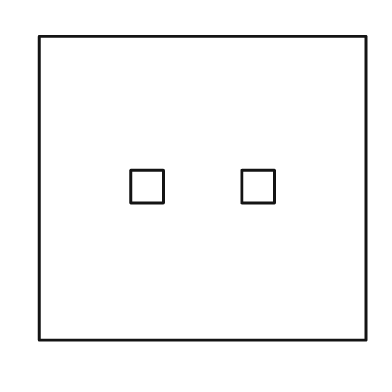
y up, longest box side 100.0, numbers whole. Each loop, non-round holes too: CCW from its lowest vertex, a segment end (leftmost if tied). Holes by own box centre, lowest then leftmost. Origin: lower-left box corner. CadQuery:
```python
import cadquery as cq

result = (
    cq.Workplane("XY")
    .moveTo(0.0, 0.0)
    .lineTo(100.0, 0.0)
    .lineTo(100.0, 93.0)
    .lineTo(0.0, 93.0)
    .close()
    .moveTo(28.0, 42.0)
    .lineTo(38.0, 42.0)
    .lineTo(38.0, 52.0)
    .lineTo(28.0, 52.0)
    .close()
    .moveTo(62.0, 42.0)
    .lineTo(72.0, 42.0)
    .lineTo(72.0, 52.0)
    .lineTo(62.0, 52.0)
    .close()
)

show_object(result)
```